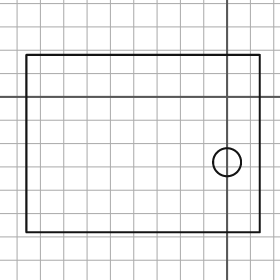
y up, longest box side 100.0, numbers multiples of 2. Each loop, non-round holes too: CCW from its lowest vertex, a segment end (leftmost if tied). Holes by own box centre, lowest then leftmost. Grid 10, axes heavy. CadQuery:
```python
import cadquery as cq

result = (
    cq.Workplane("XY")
    .moveTo(-86.0, -58.0)
    .lineTo(14.0, -58.0)
    .lineTo(14.0, 18.0)
    .lineTo(-86.0, 18.0)
    .close()
    .moveTo(0.0, -28.0)
    .circle(6.0)
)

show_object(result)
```